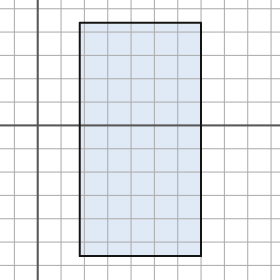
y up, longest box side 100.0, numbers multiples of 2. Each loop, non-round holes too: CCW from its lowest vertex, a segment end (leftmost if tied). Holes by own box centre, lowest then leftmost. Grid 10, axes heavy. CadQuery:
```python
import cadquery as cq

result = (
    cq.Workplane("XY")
    .moveTo(18.0, -56.0)
    .lineTo(70.0, -56.0)
    .lineTo(70.0, 44.0)
    .lineTo(18.0, 44.0)
    .close()
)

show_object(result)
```